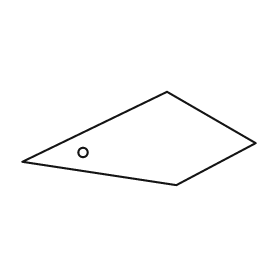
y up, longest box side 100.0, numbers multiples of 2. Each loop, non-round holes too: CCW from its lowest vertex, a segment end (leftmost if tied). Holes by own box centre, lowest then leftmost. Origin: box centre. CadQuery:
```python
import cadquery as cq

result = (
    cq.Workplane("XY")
    .moveTo(16.0, -20.0)
    .lineTo(50.0, -2.0)
    .lineTo(12.0, 20.0)
    .lineTo(-50.0, -10.0)
    .close()
    .moveTo(-24.0, -6.0)
    .circle(2.0)
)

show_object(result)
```